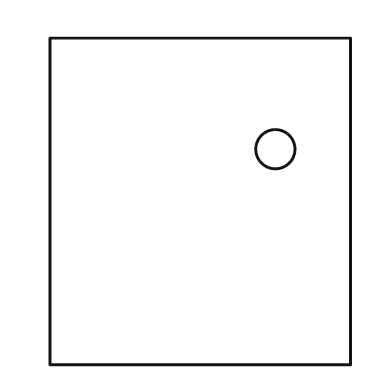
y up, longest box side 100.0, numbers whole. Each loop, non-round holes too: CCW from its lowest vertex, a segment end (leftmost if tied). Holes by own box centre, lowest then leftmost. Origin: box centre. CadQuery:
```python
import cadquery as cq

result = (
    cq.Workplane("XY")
    .moveTo(-46.0, -50.0)
    .lineTo(46.0, -50.0)
    .lineTo(46.0, 50.0)
    .lineTo(-46.0, 50.0)
    .close()
    .moveTo(23.0, 16.0)
    .circle(6.0)
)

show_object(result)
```